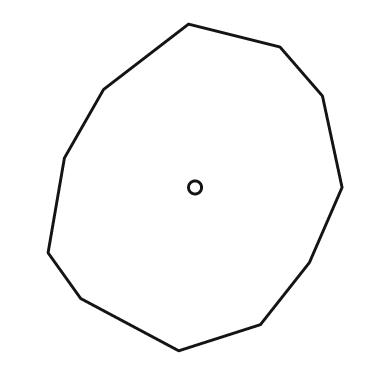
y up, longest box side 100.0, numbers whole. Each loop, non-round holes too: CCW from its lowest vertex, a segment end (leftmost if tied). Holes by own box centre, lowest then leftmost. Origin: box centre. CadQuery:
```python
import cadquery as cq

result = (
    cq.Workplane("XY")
    .moveTo(-5.0, -50.0)
    .lineTo(20.0, -42.0)
    .lineTo(35.0, -23.0)
    .lineTo(45.0, 0.0)
    .lineTo(39.0, 28.0)
    .lineTo(26.0, 43.0)
    .lineTo(-2.0, 50.0)
    .lineTo(-28.0, 30.0)
    .lineTo(-40.0, 9.0)
    .lineTo(-45.0, -20.0)
    .lineTo(-35.0, -34.0)
    .close()
    .moveTo(0.0, 0.0)
    .circle(2.0)
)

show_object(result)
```